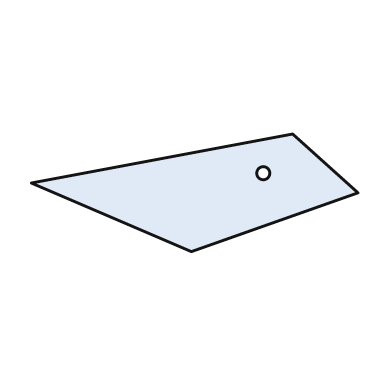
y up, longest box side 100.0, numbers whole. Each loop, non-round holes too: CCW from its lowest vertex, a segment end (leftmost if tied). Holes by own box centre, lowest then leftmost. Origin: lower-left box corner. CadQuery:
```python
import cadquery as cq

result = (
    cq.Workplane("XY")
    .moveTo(49.0, 0.0)
    .lineTo(100.0, 18.0)
    .lineTo(80.0, 36.0)
    .lineTo(0.0, 21.0)
    .close()
    .moveTo(71.0, 24.0)
    .circle(2.0)
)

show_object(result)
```